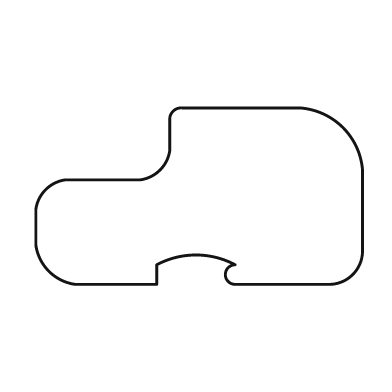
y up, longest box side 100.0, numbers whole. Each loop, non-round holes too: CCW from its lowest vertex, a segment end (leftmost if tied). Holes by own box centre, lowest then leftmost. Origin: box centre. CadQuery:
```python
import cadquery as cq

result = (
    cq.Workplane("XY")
    .moveTo(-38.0, -27.0)
    .lineTo(-13.0, -27.0)
    .lineTo(-13.0, -21.0)
    .threePointArc((-1.0, -18.0), (11.0, -21.0))
    .threePointArc((8.0, -24.0), (11.0, -27.0))
    .lineTo(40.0, -27.0)
    .threePointArc((47.0, -24.0), (50.0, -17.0))
    .lineTo(50.0, 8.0)
    .threePointArc((44.0, 21.0), (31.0, 27.0))
    .lineTo(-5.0, 27.0)
    .threePointArc((-8.0, 26.0), (-9.0, 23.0))
    .lineTo(-9.0, 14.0)
    .threePointArc((-12.0, 8.0), (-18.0, 5.0))
    .lineTo(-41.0, 5.0)
    .threePointArc((-47.0, 2.0), (-50.0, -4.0))
    .lineTo(-50.0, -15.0)
    .threePointArc((-46.0, -23.0), (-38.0, -27.0))
    .close()
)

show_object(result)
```